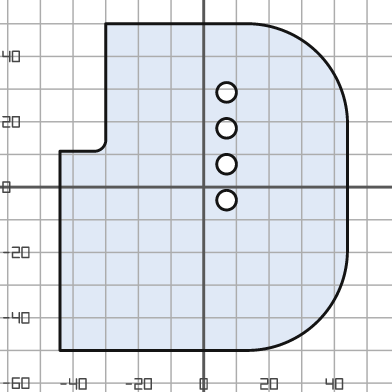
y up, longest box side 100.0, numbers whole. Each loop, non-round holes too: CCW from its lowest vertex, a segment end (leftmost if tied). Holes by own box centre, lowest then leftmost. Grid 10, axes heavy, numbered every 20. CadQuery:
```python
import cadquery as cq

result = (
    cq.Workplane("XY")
    .moveTo(-44.0, -50.0)
    .lineTo(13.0, -50.0)
    .threePointArc((35.0, -41.0), (44.0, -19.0))
    .lineTo(44.0, 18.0)
    .threePointArc((35.0, 41.0), (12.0, 50.0))
    .lineTo(-30.0, 50.0)
    .lineTo(-30.0, 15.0)
    .threePointArc((-31.0, 12.0), (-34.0, 11.0))
    .lineTo(-44.0, 11.0)
    .close()
    .moveTo(7.0, -4.0)
    .circle(3.0)
    .moveTo(7.0, 7.0)
    .circle(3.0)
    .moveTo(7.0, 18.0)
    .circle(3.0)
    .moveTo(7.0, 29.0)
    .circle(3.0)
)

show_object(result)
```